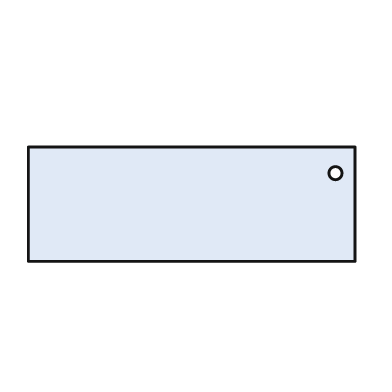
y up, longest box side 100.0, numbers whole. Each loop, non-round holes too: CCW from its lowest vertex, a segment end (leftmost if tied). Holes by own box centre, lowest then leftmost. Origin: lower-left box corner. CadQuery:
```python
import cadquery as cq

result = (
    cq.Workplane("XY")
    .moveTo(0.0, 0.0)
    .lineTo(100.0, 0.0)
    .lineTo(100.0, 35.0)
    .lineTo(0.0, 35.0)
    .close()
    .moveTo(94.0, 27.0)
    .circle(2.0)
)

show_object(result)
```